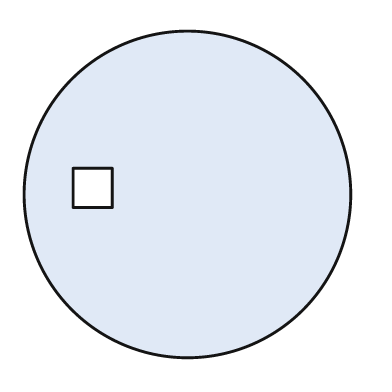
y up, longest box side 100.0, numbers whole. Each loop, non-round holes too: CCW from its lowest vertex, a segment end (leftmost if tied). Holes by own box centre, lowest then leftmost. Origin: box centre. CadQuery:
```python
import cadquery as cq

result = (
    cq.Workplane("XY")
    .moveTo(0.0, 0.0)
    .circle(50.0)
    .moveTo(-35.0, -4.0)
    .lineTo(-23.0, -4.0)
    .lineTo(-23.0, 8.0)
    .lineTo(-35.0, 8.0)
    .close()
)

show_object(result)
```